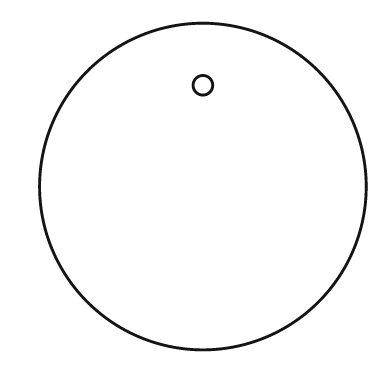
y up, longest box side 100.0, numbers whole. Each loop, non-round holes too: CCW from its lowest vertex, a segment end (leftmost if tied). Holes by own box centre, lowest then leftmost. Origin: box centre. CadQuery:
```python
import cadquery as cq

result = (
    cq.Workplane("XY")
    .moveTo(0.0, 0.0)
    .circle(50.0)
    .moveTo(0.0, 31.0)
    .circle(3.0)
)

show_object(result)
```